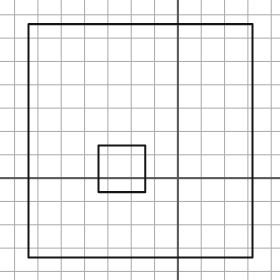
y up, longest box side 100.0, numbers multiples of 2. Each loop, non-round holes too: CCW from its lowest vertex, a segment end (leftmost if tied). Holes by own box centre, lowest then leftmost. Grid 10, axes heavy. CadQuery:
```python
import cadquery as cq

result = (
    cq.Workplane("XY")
    .moveTo(-64.0, -34.0)
    .lineTo(32.0, -34.0)
    .lineTo(32.0, 66.0)
    .lineTo(-64.0, 66.0)
    .close()
    .moveTo(-34.0, -6.0)
    .lineTo(-14.0, -6.0)
    .lineTo(-14.0, 14.0)
    .lineTo(-34.0, 14.0)
    .close()
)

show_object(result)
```